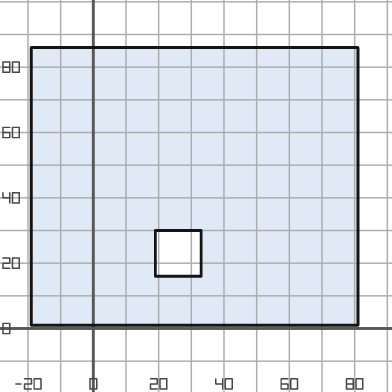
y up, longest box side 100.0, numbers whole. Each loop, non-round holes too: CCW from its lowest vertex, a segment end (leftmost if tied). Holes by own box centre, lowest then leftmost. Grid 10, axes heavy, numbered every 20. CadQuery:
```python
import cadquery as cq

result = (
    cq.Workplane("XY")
    .moveTo(-19.0, 1.0)
    .lineTo(81.0, 1.0)
    .lineTo(81.0, 86.0)
    .lineTo(-19.0, 86.0)
    .close()
    .moveTo(19.0, 16.0)
    .lineTo(33.0, 16.0)
    .lineTo(33.0, 30.0)
    .lineTo(19.0, 30.0)
    .close()
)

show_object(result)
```